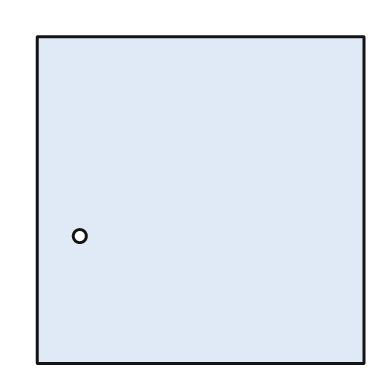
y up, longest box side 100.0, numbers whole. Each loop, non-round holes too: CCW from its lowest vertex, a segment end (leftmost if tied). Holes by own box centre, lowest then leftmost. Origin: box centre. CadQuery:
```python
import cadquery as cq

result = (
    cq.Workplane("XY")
    .moveTo(-50.0, -50.0)
    .lineTo(50.0, -50.0)
    .lineTo(50.0, 50.0)
    .lineTo(-50.0, 50.0)
    .close()
    .moveTo(-37.0, -11.0)
    .circle(2.0)
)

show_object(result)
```